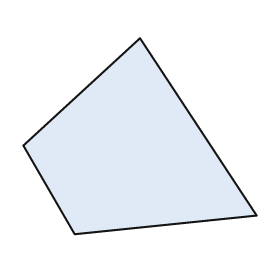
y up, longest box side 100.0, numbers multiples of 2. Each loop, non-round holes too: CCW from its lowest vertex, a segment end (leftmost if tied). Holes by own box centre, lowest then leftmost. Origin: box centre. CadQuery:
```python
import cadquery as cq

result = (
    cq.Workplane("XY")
    .moveTo(-28.0, -42.0)
    .lineTo(50.0, -34.0)
    .lineTo(0.0, 42.0)
    .lineTo(-50.0, -4.0)
    .close()
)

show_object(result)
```